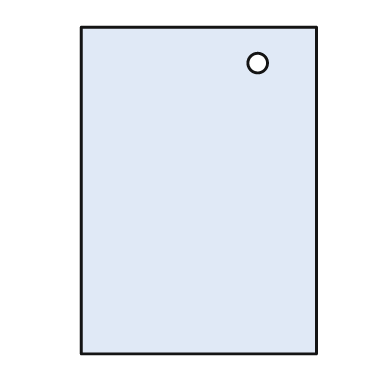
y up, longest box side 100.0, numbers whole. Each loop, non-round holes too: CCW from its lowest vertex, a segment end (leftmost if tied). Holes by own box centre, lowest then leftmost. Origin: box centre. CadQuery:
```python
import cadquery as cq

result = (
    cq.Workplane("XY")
    .moveTo(-36.0, -50.0)
    .lineTo(36.0, -50.0)
    .lineTo(36.0, 50.0)
    .lineTo(-36.0, 50.0)
    .close()
    .moveTo(18.0, 39.0)
    .circle(3.0)
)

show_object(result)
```